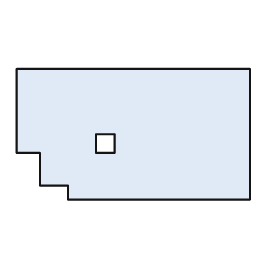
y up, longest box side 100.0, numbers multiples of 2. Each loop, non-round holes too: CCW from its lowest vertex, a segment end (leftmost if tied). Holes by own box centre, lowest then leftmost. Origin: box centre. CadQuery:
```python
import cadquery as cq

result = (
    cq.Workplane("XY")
    .moveTo(-28.0, -28.0)
    .lineTo(50.0, -28.0)
    .lineTo(50.0, 28.0)
    .lineTo(-50.0, 28.0)
    .lineTo(-50.0, -8.0)
    .lineTo(-40.0, -8.0)
    .lineTo(-40.0, -22.0)
    .lineTo(-28.0, -22.0)
    .close()
    .moveTo(-16.0, -8.0)
    .lineTo(-8.0, -8.0)
    .lineTo(-8.0, 0.0)
    .lineTo(-16.0, 0.0)
    .close()
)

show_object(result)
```